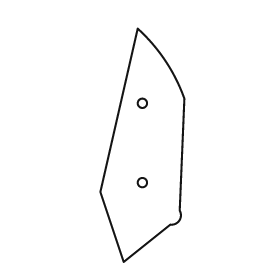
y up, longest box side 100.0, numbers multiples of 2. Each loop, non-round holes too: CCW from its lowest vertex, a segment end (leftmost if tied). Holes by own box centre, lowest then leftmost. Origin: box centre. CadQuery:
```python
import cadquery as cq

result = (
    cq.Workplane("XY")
    .moveTo(-8.0, -50.0)
    .lineTo(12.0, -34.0)
    .threePointArc((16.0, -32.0), (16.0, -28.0))
    .lineTo(18.0, 20.0)
    .threePointArc((10.0, 36.0), (-2.0, 50.0))
    .lineTo(-18.0, -20.0)
    .close()
    .moveTo(0.0, -16.0)
    .circle(2.0)
    .moveTo(0.0, 18.0)
    .circle(2.0)
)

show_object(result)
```